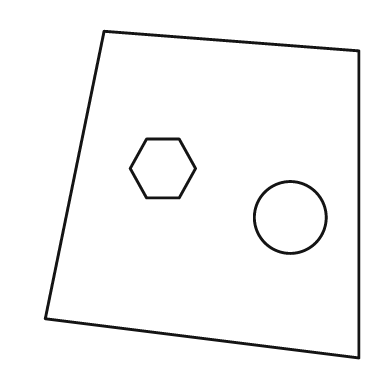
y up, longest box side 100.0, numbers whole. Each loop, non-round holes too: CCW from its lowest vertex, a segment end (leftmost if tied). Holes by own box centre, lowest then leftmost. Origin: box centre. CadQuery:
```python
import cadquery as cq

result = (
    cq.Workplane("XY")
    .moveTo(48.0, -50.0)
    .lineTo(48.0, 44.0)
    .lineTo(-30.0, 50.0)
    .lineTo(-48.0, -38.0)
    .close()
    .moveTo(27.0, -7.0)
    .circle(11.0)
    .moveTo(-17.0, -1.0)
    .lineTo(-7.0, -1.0)
    .lineTo(-2.0, 8.0)
    .lineTo(-7.0, 17.0)
    .lineTo(-17.0, 17.0)
    .lineTo(-22.0, 8.0)
    .close()
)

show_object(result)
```